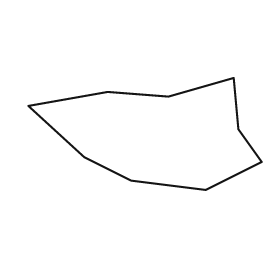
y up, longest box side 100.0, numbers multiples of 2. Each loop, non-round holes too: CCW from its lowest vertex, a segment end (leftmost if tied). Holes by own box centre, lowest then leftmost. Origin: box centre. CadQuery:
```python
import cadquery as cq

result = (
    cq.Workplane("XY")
    .moveTo(26.0, -24.0)
    .lineTo(50.0, -12.0)
    .lineTo(40.0, 2.0)
    .lineTo(38.0, 24.0)
    .lineTo(10.0, 16.0)
    .lineTo(-16.0, 18.0)
    .lineTo(-50.0, 12.0)
    .lineTo(-26.0, -10.0)
    .lineTo(-6.0, -20.0)
    .close()
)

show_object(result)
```